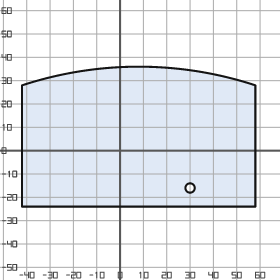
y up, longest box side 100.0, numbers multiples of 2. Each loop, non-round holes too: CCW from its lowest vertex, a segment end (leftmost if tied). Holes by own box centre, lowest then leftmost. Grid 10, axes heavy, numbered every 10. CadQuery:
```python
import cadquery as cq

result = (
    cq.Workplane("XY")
    .moveTo(-42.0, -24.0)
    .lineTo(58.0, -24.0)
    .lineTo(58.0, 28.0)
    .threePointArc((8.0, 36.0), (-42.0, 28.0))
    .close()
    .moveTo(30.0, -16.0)
    .circle(2.0)
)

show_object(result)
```